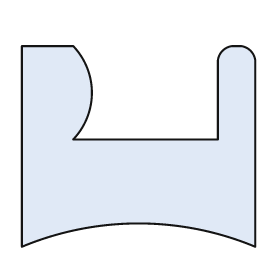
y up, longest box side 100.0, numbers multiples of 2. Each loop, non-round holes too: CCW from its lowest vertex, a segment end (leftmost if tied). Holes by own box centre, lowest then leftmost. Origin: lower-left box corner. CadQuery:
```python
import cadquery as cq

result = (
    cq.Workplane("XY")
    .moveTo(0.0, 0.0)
    .threePointArc((50.0, 10.0), (100.0, 0.0))
    .lineTo(100.0, 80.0)
    .threePointArc((98.0, 84.0), (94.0, 86.0))
    .lineTo(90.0, 86.0)
    .threePointArc((86.0, 84.0), (84.0, 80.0))
    .lineTo(84.0, 46.0)
    .lineTo(22.0, 46.0)
    .threePointArc((30.0, 66.0), (22.0, 86.0))
    .lineTo(0.0, 86.0)
    .close()
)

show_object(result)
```